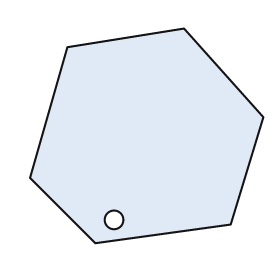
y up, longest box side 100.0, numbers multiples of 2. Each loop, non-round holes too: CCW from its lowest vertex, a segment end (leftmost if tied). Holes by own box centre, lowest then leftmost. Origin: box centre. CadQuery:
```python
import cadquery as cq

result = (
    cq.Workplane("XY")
    .moveTo(-22.0, -46.0)
    .lineTo(36.0, -38.0)
    .lineTo(50.0, 8.0)
    .lineTo(16.0, 46.0)
    .lineTo(-34.0, 38.0)
    .lineTo(-50.0, -18.0)
    .close()
    .moveTo(-14.0, -36.0)
    .circle(4.0)
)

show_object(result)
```